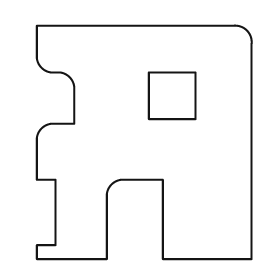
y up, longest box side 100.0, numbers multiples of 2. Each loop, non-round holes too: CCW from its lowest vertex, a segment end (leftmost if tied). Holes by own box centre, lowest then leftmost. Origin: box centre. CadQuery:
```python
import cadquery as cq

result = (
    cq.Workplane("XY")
    .moveTo(-46.0, -50.0)
    .lineTo(-16.0, -50.0)
    .lineTo(-16.0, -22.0)
    .threePointArc((-14.0, -18.0), (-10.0, -16.0))
    .lineTo(8.0, -16.0)
    .lineTo(8.0, -50.0)
    .lineTo(46.0, -50.0)
    .lineTo(46.0, 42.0)
    .threePointArc((44.0, 48.0), (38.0, 50.0))
    .lineTo(-46.0, 50.0)
    .lineTo(-46.0, 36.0)
    .threePointArc((-44.0, 32.0), (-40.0, 30.0))
    .lineTo(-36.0, 30.0)
    .threePointArc((-32.0, 28.0), (-30.0, 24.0))
    .lineTo(-30.0, 8.0)
    .lineTo(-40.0, 8.0)
    .threePointArc((-44.0, 6.0), (-46.0, 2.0))
    .lineTo(-46.0, -16.0)
    .lineTo(-38.0, -16.0)
    .lineTo(-38.0, -44.0)
    .lineTo(-46.0, -44.0)
    .close()
    .moveTo(2.0, 10.0)
    .lineTo(22.0, 10.0)
    .lineTo(22.0, 30.0)
    .lineTo(2.0, 30.0)
    .close()
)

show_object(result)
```